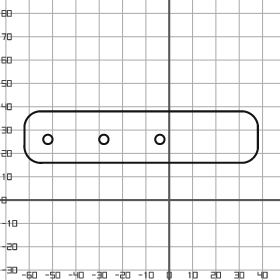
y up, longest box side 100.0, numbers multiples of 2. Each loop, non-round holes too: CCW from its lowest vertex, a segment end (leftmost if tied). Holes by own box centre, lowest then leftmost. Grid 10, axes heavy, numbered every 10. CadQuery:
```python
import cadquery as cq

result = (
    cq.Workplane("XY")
    .moveTo(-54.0, 16.0)
    .lineTo(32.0, 16.0)
    .threePointArc((36.0, 18.0), (38.0, 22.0))
    .lineTo(38.0, 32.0)
    .threePointArc((36.0, 36.0), (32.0, 38.0))
    .lineTo(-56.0, 38.0)
    .threePointArc((-60.0, 36.0), (-62.0, 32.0))
    .lineTo(-62.0, 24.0)
    .threePointArc((-60.0, 18.0), (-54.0, 16.0))
    .close()
    .moveTo(-52.0, 26.0)
    .circle(2.0)
    .moveTo(-28.0, 26.0)
    .circle(2.0)
    .moveTo(-4.0, 26.0)
    .circle(2.0)
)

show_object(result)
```